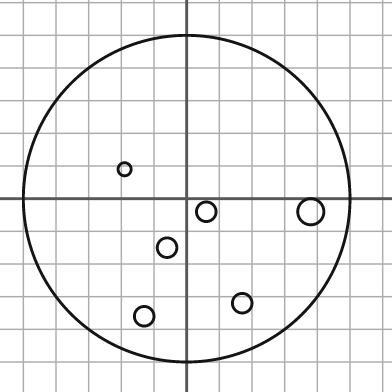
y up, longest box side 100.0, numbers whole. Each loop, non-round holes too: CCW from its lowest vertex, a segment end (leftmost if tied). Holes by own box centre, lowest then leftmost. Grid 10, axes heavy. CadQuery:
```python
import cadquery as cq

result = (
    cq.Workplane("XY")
    .moveTo(0.0, 0.0)
    .circle(50.0)
    .moveTo(-13.0, -36.0)
    .circle(3.0)
    .moveTo(17.0, -32.0)
    .circle(3.0)
    .moveTo(-6.0, -15.0)
    .circle(3.0)
    .moveTo(6.0, -4.0)
    .circle(3.0)
    .moveTo(38.0, -4.0)
    .circle(4.0)
    .moveTo(-19.0, 9.0)
    .circle(2.0)
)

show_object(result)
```